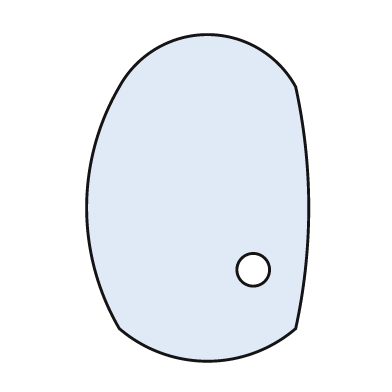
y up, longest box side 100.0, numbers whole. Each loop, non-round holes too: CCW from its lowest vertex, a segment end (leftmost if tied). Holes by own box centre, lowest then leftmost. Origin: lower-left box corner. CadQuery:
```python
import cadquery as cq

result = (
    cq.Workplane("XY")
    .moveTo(10.0, 10.0)
    .threePointArc((37.0, 0.0), (64.0, 10.0))
    .threePointArc((68.0, 47.0), (64.0, 84.0))
    .threePointArc((37.0, 100.0), (10.0, 84.0))
    .threePointArc((0.0, 47.0), (10.0, 10.0))
    .close()
    .moveTo(51.0, 28.0)
    .circle(5.0)
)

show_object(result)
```